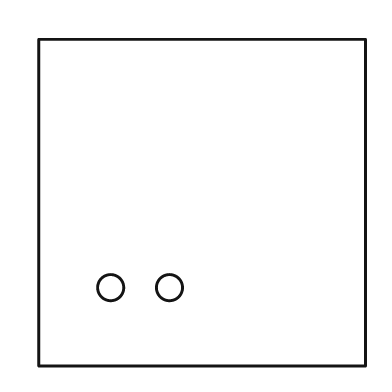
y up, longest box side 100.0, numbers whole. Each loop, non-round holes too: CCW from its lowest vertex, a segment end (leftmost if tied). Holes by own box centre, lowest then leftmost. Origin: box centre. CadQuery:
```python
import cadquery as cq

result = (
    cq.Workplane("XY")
    .moveTo(-50.0, -50.0)
    .lineTo(50.0, -50.0)
    .lineTo(50.0, 50.0)
    .lineTo(-50.0, 50.0)
    .close()
    .moveTo(-28.0, -26.0)
    .circle(4.0)
    .moveTo(-10.0, -26.0)
    .circle(4.0)
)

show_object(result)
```